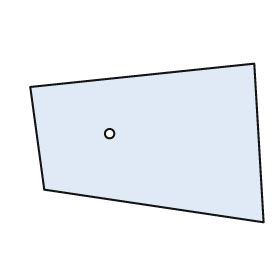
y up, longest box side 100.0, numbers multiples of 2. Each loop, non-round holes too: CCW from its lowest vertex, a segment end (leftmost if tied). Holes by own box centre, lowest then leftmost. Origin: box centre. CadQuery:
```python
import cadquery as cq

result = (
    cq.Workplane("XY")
    .moveTo(50.0, -34.0)
    .lineTo(46.0, 34.0)
    .lineTo(-50.0, 24.0)
    .lineTo(-44.0, -20.0)
    .close()
    .moveTo(-16.0, 4.0)
    .circle(2.0)
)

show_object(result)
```